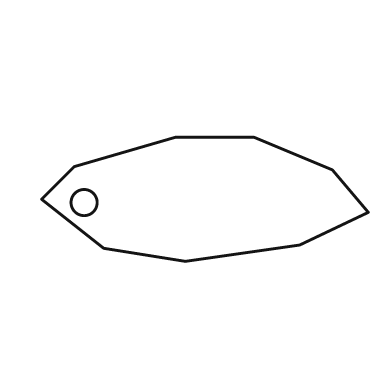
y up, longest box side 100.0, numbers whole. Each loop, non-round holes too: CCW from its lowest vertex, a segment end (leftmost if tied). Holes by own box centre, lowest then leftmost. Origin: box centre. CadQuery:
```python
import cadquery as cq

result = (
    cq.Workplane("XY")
    .moveTo(-6.0, -19.0)
    .lineTo(29.0, -14.0)
    .lineTo(50.0, -4.0)
    .lineTo(39.0, 9.0)
    .lineTo(15.0, 19.0)
    .lineTo(-9.0, 19.0)
    .lineTo(-40.0, 10.0)
    .lineTo(-50.0, 0.0)
    .lineTo(-31.0, -15.0)
    .close()
    .moveTo(-37.0, -1.0)
    .circle(4.0)
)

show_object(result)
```